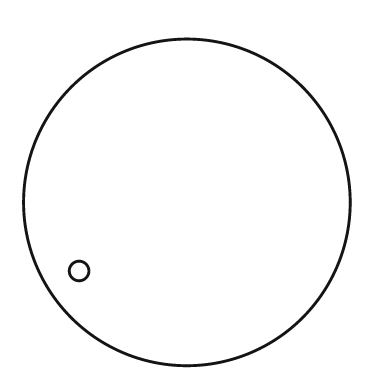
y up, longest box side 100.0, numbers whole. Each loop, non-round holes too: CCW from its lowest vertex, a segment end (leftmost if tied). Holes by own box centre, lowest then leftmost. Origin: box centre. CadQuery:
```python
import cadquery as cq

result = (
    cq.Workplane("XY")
    .moveTo(0.0, 0.0)
    .circle(50.0)
    .moveTo(-33.0, -21.0)
    .circle(3.0)
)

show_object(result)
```